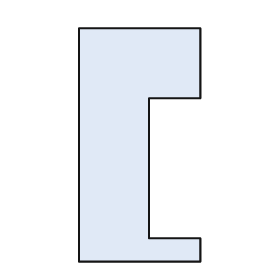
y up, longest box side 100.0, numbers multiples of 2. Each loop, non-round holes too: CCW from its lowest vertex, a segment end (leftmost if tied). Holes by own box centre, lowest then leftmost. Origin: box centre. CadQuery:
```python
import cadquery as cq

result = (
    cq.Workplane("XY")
    .moveTo(-26.0, -50.0)
    .lineTo(26.0, -50.0)
    .lineTo(26.0, -40.0)
    .lineTo(4.0, -40.0)
    .lineTo(4.0, 20.0)
    .lineTo(26.0, 20.0)
    .lineTo(26.0, 50.0)
    .lineTo(-26.0, 50.0)
    .close()
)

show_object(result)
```